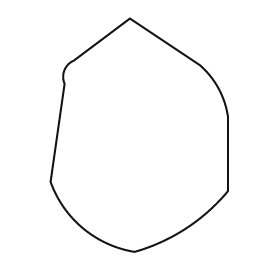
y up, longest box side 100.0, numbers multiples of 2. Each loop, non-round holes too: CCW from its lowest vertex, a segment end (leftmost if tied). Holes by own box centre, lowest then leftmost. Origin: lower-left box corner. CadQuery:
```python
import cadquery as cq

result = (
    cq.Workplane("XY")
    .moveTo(36.0, 0.0)
    .threePointArc((58.0, 10.0), (76.0, 26.0))
    .lineTo(76.0, 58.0)
    .threePointArc((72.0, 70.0), (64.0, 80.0))
    .lineTo(34.0, 100.0)
    .lineTo(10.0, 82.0)
    .threePointArc((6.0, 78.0), (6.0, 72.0))
    .lineTo(0.0, 30.0)
    .threePointArc((14.0, 10.0), (36.0, 0.0))
    .close()
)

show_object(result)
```